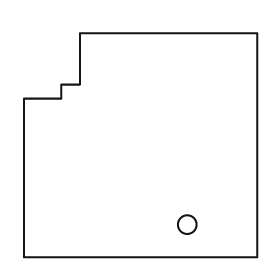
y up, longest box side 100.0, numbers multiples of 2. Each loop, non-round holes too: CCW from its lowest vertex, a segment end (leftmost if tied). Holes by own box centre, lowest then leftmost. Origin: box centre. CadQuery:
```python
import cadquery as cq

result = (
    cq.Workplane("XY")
    .moveTo(-50.0, -48.0)
    .lineTo(50.0, -48.0)
    .lineTo(50.0, 48.0)
    .lineTo(-26.0, 48.0)
    .lineTo(-26.0, 26.0)
    .lineTo(-34.0, 26.0)
    .lineTo(-34.0, 20.0)
    .lineTo(-50.0, 20.0)
    .close()
    .moveTo(20.0, -34.0)
    .circle(4.0)
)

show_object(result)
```